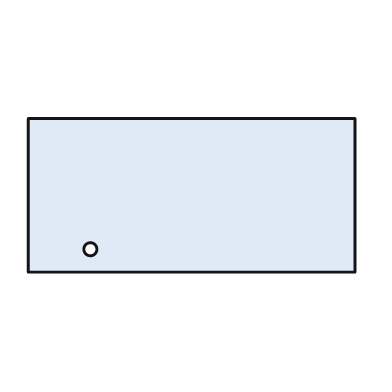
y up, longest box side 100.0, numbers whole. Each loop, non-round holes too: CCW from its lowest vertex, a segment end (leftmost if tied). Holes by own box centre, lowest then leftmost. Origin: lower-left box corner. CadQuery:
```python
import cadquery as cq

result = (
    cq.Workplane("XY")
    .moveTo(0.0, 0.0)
    .lineTo(100.0, 0.0)
    .lineTo(100.0, 47.0)
    .lineTo(0.0, 47.0)
    .close()
    .moveTo(19.0, 7.0)
    .circle(2.0)
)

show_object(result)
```